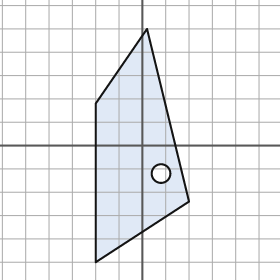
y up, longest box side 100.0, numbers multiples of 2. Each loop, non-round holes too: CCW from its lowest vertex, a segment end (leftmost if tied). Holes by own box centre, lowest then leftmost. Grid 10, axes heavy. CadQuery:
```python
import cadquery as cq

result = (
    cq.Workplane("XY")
    .moveTo(-20.0, -50.0)
    .lineTo(20.0, -24.0)
    .lineTo(2.0, 50.0)
    .lineTo(-20.0, 18.0)
    .close()
    .moveTo(8.0, -12.0)
    .circle(4.0)
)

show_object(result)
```